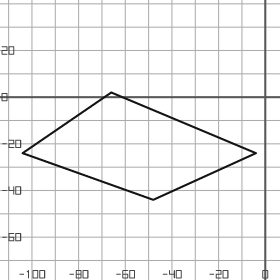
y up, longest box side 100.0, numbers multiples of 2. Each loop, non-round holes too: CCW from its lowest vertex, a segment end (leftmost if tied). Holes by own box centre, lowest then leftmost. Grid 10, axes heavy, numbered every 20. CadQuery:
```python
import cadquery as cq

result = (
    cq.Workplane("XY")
    .moveTo(-48.0, -44.0)
    .lineTo(-4.0, -24.0)
    .lineTo(-66.0, 2.0)
    .lineTo(-104.0, -24.0)
    .close()
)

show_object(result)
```